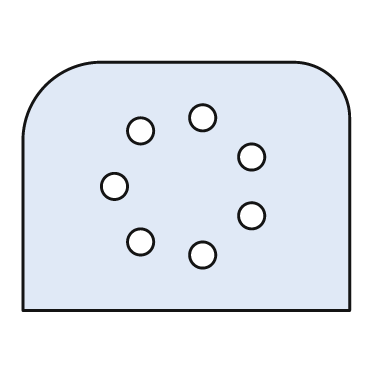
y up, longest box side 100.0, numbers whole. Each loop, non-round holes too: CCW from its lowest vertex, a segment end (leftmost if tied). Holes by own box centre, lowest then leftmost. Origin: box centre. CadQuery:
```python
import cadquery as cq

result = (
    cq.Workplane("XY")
    .moveTo(-50.0, -38.0)
    .lineTo(50.0, -38.0)
    .lineTo(50.0, 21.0)
    .threePointArc((45.0, 33.0), (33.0, 38.0))
    .lineTo(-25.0, 38.0)
    .threePointArc((-43.0, 31.0), (-50.0, 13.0))
    .close()
    .moveTo(5.0, -21.0)
    .circle(4.0)
    .moveTo(-14.0, -17.0)
    .circle(4.0)
    .moveTo(20.0, -9.0)
    .circle(4.0)
    .moveTo(-22.0, 0.0)
    .circle(4.0)
    .moveTo(20.0, 9.0)
    .circle(4.0)
    .moveTo(-14.0, 17.0)
    .circle(4.0)
    .moveTo(5.0, 21.0)
    .circle(4.0)
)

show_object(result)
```